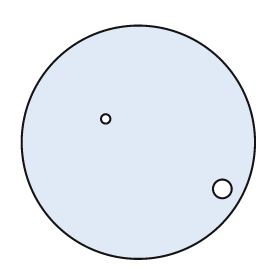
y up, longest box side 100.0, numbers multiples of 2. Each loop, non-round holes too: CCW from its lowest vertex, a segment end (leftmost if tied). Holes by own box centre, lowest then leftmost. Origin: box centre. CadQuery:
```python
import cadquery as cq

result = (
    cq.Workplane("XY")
    .moveTo(0.0, 0.0)
    .circle(50.0)
    .moveTo(36.0, -20.0)
    .circle(4.0)
    .moveTo(-14.0, 10.0)
    .circle(2.0)
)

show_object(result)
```